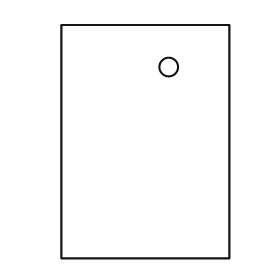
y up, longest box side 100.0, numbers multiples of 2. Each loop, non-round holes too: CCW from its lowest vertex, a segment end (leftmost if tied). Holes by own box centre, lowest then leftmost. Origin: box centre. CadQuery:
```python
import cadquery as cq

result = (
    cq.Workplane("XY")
    .moveTo(-36.0, -50.0)
    .lineTo(36.0, -50.0)
    .lineTo(36.0, 50.0)
    .lineTo(-36.0, 50.0)
    .close()
    .moveTo(10.0, 32.0)
    .circle(4.0)
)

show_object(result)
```